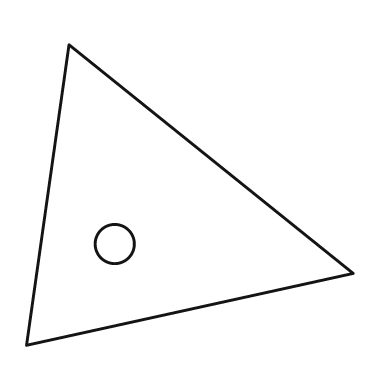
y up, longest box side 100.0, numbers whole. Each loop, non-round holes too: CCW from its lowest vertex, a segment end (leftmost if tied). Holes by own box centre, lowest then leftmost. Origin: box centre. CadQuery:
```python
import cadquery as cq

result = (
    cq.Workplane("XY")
    .moveTo(-50.0, -46.0)
    .lineTo(50.0, -24.0)
    .lineTo(-37.0, 46.0)
    .close()
    .moveTo(-23.0, -15.0)
    .circle(6.0)
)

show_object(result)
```